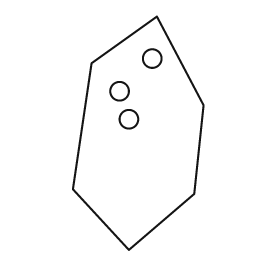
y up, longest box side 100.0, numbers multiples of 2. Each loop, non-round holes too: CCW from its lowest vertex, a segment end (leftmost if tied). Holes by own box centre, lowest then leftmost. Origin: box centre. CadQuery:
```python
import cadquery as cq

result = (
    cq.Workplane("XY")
    .moveTo(-4.0, -50.0)
    .lineTo(24.0, -26.0)
    .lineTo(28.0, 12.0)
    .lineTo(8.0, 50.0)
    .lineTo(-20.0, 30.0)
    .lineTo(-28.0, -24.0)
    .close()
    .moveTo(-4.0, 6.0)
    .circle(4.0)
    .moveTo(-8.0, 18.0)
    .circle(4.0)
    .moveTo(6.0, 32.0)
    .circle(4.0)
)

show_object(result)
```